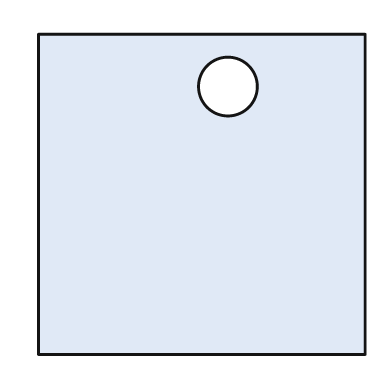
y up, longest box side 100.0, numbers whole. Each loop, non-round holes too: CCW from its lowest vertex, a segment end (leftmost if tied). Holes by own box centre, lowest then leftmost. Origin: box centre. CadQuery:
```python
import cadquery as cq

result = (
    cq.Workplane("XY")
    .moveTo(-50.0, -49.0)
    .lineTo(50.0, -49.0)
    .lineTo(50.0, 49.0)
    .lineTo(-50.0, 49.0)
    .close()
    .moveTo(8.0, 33.0)
    .circle(9.0)
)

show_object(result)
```